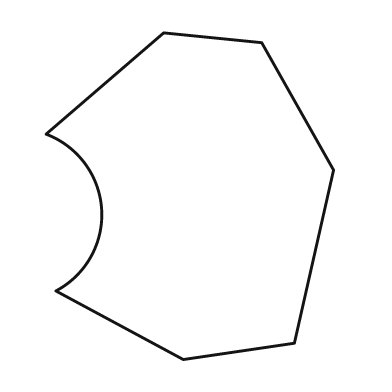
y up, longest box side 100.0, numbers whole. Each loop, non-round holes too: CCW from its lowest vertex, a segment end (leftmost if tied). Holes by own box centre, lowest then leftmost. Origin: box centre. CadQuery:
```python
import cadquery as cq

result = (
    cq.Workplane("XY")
    .moveTo(-2.0, -50.0)
    .lineTo(32.0, -45.0)
    .lineTo(44.0, 8.0)
    .lineTo(22.0, 47.0)
    .lineTo(-8.0, 50.0)
    .lineTo(-44.0, 19.0)
    .threePointArc((-27.0, -4.0), (-41.0, -29.0))
    .close()
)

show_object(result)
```